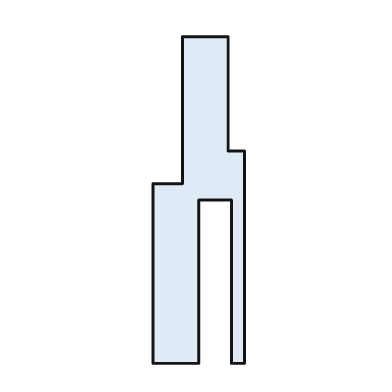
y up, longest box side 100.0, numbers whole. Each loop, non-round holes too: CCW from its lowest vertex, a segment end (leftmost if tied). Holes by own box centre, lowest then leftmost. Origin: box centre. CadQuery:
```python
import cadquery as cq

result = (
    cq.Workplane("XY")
    .moveTo(-14.0, -50.0)
    .lineTo(0.0, -50.0)
    .lineTo(0.0, 0.0)
    .lineTo(10.0, 0.0)
    .lineTo(10.0, -50.0)
    .lineTo(14.0, -50.0)
    .lineTo(14.0, 15.0)
    .lineTo(9.0, 15.0)
    .lineTo(9.0, 50.0)
    .lineTo(-5.0, 50.0)
    .lineTo(-5.0, 5.0)
    .lineTo(-14.0, 5.0)
    .close()
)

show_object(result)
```